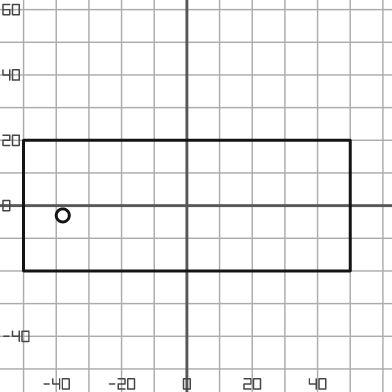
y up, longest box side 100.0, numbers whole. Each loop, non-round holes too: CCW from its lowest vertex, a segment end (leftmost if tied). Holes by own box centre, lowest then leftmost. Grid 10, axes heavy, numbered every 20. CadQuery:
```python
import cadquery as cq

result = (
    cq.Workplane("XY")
    .moveTo(-50.0, -20.0)
    .lineTo(50.0, -20.0)
    .lineTo(50.0, 20.0)
    .lineTo(-50.0, 20.0)
    .close()
    .moveTo(-38.0, -3.0)
    .circle(2.0)
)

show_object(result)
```